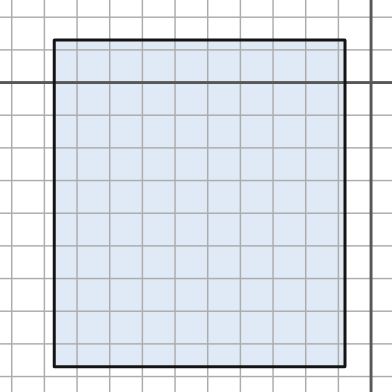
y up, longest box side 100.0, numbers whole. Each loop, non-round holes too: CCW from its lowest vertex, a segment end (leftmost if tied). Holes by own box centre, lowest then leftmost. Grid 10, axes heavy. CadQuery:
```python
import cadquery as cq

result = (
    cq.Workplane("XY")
    .moveTo(-97.0, -87.0)
    .lineTo(-8.0, -87.0)
    .lineTo(-8.0, 13.0)
    .lineTo(-97.0, 13.0)
    .close()
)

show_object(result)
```